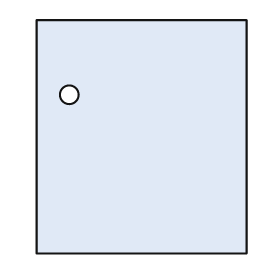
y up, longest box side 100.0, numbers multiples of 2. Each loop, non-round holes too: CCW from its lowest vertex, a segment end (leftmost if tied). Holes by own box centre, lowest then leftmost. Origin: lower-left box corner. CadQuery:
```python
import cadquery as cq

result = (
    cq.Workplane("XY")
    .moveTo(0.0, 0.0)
    .lineTo(90.0, 0.0)
    .lineTo(90.0, 100.0)
    .lineTo(0.0, 100.0)
    .close()
    .moveTo(14.0, 68.0)
    .circle(4.0)
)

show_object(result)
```